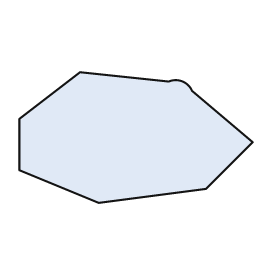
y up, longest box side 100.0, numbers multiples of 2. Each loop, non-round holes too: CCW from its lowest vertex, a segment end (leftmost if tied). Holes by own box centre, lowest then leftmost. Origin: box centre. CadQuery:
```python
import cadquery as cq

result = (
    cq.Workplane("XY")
    .moveTo(-16.0, -28.0)
    .lineTo(30.0, -22.0)
    .lineTo(50.0, -2.0)
    .lineTo(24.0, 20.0)
    .threePointArc((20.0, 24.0), (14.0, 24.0))
    .lineTo(-24.0, 28.0)
    .lineTo(-50.0, 8.0)
    .lineTo(-50.0, -14.0)
    .close()
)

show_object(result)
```